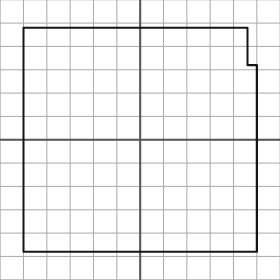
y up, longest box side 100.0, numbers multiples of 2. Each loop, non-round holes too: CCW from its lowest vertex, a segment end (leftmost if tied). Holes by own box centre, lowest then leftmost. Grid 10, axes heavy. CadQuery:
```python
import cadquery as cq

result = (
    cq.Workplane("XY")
    .moveTo(-50.0, -48.0)
    .lineTo(50.0, -48.0)
    .lineTo(50.0, 32.0)
    .lineTo(46.0, 32.0)
    .lineTo(46.0, 48.0)
    .lineTo(-50.0, 48.0)
    .close()
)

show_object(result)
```